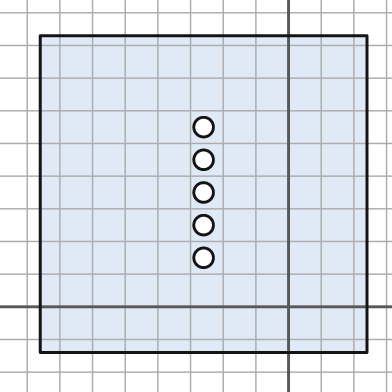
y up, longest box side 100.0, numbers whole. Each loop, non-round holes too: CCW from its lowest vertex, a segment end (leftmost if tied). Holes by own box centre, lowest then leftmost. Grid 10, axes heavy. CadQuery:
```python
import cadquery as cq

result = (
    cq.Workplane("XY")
    .moveTo(-76.0, -14.0)
    .lineTo(24.0, -14.0)
    .lineTo(24.0, 83.0)
    .lineTo(-76.0, 83.0)
    .close()
    .moveTo(-26.0, 15.0)
    .circle(3.0)
    .moveTo(-26.0, 25.0)
    .circle(3.0)
    .moveTo(-26.0, 35.0)
    .circle(3.0)
    .moveTo(-26.0, 45.0)
    .circle(3.0)
    .moveTo(-26.0, 55.0)
    .circle(3.0)
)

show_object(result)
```